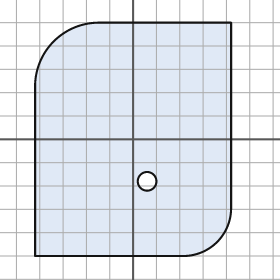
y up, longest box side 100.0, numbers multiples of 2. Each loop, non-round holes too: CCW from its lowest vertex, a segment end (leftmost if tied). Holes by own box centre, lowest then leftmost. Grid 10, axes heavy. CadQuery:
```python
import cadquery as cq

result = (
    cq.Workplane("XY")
    .moveTo(-42.0, -50.0)
    .lineTo(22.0, -50.0)
    .threePointArc((36.0, -44.0), (42.0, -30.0))
    .lineTo(42.0, 50.0)
    .lineTo(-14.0, 50.0)
    .threePointArc((-34.0, 42.0), (-42.0, 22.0))
    .close()
    .moveTo(6.0, -18.0)
    .circle(4.0)
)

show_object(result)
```